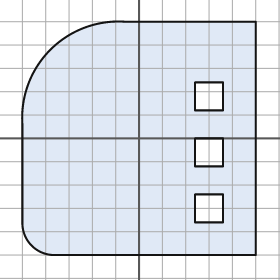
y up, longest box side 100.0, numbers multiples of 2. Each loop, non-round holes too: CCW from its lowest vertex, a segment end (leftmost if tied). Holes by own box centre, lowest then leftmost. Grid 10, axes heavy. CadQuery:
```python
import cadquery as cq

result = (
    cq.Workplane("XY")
    .moveTo(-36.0, -50.0)
    .lineTo(50.0, -50.0)
    .lineTo(50.0, 50.0)
    .lineTo(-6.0, 50.0)
    .threePointArc((-38.0, 38.0), (-50.0, 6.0))
    .lineTo(-50.0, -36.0)
    .threePointArc((-46.0, -46.0), (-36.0, -50.0))
    .close()
    .moveTo(24.0, -36.0)
    .lineTo(36.0, -36.0)
    .lineTo(36.0, -24.0)
    .lineTo(24.0, -24.0)
    .close()
    .moveTo(24.0, -12.0)
    .lineTo(36.0, -12.0)
    .lineTo(36.0, 0.0)
    .lineTo(24.0, 0.0)
    .close()
    .moveTo(24.0, 12.0)
    .lineTo(36.0, 12.0)
    .lineTo(36.0, 24.0)
    .lineTo(24.0, 24.0)
    .close()
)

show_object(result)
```